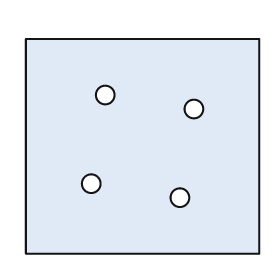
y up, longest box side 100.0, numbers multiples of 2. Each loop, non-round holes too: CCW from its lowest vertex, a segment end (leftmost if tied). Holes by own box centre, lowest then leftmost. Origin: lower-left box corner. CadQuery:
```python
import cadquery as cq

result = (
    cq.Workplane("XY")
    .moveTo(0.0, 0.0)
    .lineTo(100.0, 0.0)
    .lineTo(100.0, 92.0)
    .lineTo(0.0, 92.0)
    .close()
    .moveTo(66.0, 24.0)
    .circle(4.0)
    .moveTo(28.0, 30.0)
    .circle(4.0)
    .moveTo(72.0, 62.0)
    .circle(4.0)
    .moveTo(34.0, 68.0)
    .circle(4.0)
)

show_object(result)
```